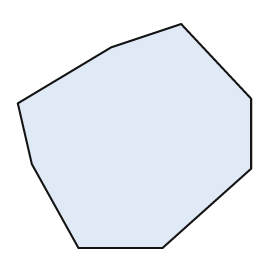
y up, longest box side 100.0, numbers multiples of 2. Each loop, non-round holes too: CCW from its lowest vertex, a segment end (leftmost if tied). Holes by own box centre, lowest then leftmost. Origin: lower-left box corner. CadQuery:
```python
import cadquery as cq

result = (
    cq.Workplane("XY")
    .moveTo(26.0, 0.0)
    .lineTo(62.0, 0.0)
    .lineTo(100.0, 34.0)
    .lineTo(100.0, 64.0)
    .lineTo(70.0, 96.0)
    .lineTo(40.0, 86.0)
    .lineTo(0.0, 62.0)
    .lineTo(6.0, 36.0)
    .close()
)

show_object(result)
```